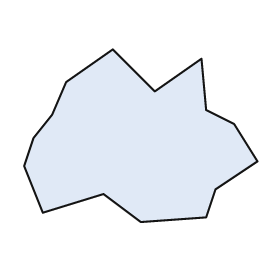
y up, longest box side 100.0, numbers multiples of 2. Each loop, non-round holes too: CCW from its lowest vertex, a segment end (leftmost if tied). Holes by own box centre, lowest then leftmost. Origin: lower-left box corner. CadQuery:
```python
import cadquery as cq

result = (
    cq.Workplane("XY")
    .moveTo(50.0, 0.0)
    .lineTo(78.0, 2.0)
    .lineTo(82.0, 14.0)
    .lineTo(100.0, 26.0)
    .lineTo(90.0, 42.0)
    .lineTo(78.0, 48.0)
    .lineTo(76.0, 70.0)
    .lineTo(56.0, 56.0)
    .lineTo(38.0, 74.0)
    .lineTo(18.0, 60.0)
    .lineTo(12.0, 46.0)
    .lineTo(4.0, 36.0)
    .lineTo(0.0, 24.0)
    .lineTo(8.0, 4.0)
    .lineTo(34.0, 12.0)
    .close()
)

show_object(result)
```